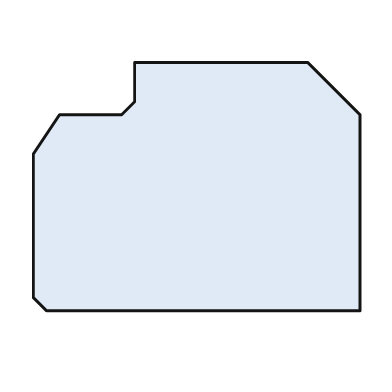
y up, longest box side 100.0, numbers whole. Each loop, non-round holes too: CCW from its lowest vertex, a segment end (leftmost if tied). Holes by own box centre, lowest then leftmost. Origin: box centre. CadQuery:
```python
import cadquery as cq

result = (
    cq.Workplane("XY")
    .moveTo(-46.0, -38.0)
    .lineTo(50.0, -38.0)
    .lineTo(50.0, 22.0)
    .lineTo(34.0, 38.0)
    .lineTo(-19.0, 38.0)
    .lineTo(-19.0, 26.0)
    .lineTo(-23.0, 22.0)
    .lineTo(-42.0, 22.0)
    .lineTo(-50.0, 10.0)
    .lineTo(-50.0, -34.0)
    .close()
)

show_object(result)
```